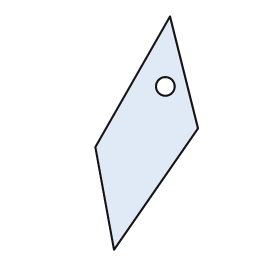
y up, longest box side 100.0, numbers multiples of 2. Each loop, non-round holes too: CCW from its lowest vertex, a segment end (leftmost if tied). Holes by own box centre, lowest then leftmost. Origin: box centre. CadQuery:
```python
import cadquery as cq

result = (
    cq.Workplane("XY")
    .moveTo(-14.0, -50.0)
    .lineTo(22.0, 2.0)
    .lineTo(10.0, 50.0)
    .lineTo(-22.0, -6.0)
    .close()
    .moveTo(8.0, 20.0)
    .circle(4.0)
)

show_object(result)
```